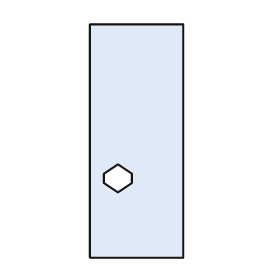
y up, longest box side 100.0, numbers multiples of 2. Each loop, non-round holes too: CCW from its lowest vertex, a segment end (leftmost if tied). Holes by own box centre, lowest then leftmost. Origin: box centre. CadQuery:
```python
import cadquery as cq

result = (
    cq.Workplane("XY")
    .moveTo(-20.0, -50.0)
    .lineTo(20.0, -50.0)
    .lineTo(20.0, 50.0)
    .lineTo(-20.0, 50.0)
    .close()
    .moveTo(-8.0, -22.0)
    .lineTo(-2.0, -18.0)
    .lineTo(-2.0, -14.0)
    .lineTo(-8.0, -10.0)
    .lineTo(-14.0, -14.0)
    .lineTo(-14.0, -18.0)
    .close()
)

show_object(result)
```